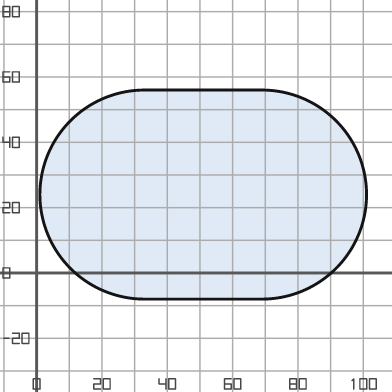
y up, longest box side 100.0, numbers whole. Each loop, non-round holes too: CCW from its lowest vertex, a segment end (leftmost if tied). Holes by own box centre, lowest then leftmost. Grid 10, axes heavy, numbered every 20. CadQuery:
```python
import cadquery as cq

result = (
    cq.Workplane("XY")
    .moveTo(33.0, -8.0)
    .lineTo(69.0, -8.0)
    .threePointArc((101.0, 24.0), (69.0, 56.0))
    .lineTo(33.0, 56.0)
    .threePointArc((1.0, 24.0), (33.0, -8.0))
    .close()
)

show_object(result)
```